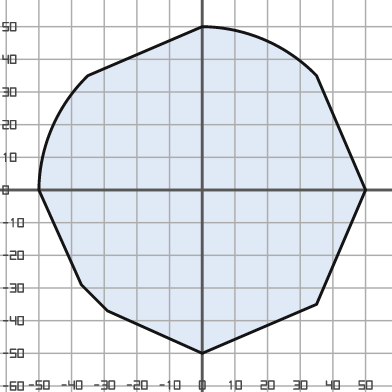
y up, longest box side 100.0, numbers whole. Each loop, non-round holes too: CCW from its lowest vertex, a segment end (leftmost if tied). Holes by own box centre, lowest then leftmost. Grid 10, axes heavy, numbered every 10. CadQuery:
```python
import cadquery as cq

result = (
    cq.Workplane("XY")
    .moveTo(0.0, -50.0)
    .lineTo(35.0, -35.0)
    .lineTo(50.0, 0.0)
    .lineTo(35.0, 35.0)
    .threePointArc((19.0, 46.0), (0.0, 50.0))
    .lineTo(-35.0, 35.0)
    .threePointArc((-46.0, 19.0), (-50.0, 0.0))
    .lineTo(-37.0, -29.0)
    .lineTo(-29.0, -37.0)
    .close()
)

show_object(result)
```